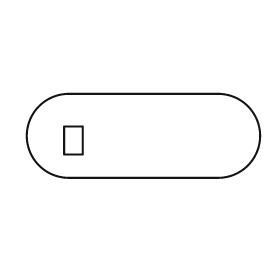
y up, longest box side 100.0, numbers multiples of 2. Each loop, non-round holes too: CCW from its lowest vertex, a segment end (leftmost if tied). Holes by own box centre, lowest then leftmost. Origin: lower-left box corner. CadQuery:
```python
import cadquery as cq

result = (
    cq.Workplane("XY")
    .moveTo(18.0, 0.0)
    .lineTo(82.0, 0.0)
    .threePointArc((100.0, 18.0), (82.0, 36.0))
    .lineTo(18.0, 36.0)
    .threePointArc((0.0, 18.0), (18.0, 0.0))
    .close()
    .moveTo(16.0, 10.0)
    .lineTo(24.0, 10.0)
    .lineTo(24.0, 22.0)
    .lineTo(16.0, 22.0)
    .close()
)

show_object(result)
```